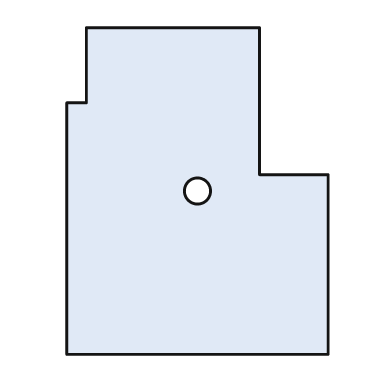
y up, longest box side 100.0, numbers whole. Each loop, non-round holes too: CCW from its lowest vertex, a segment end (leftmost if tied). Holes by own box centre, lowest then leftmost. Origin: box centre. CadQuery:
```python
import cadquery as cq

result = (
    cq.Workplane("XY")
    .moveTo(-40.0, -50.0)
    .lineTo(40.0, -50.0)
    .lineTo(40.0, 5.0)
    .lineTo(19.0, 5.0)
    .lineTo(19.0, 50.0)
    .lineTo(-34.0, 50.0)
    .lineTo(-34.0, 27.0)
    .lineTo(-40.0, 27.0)
    .close()
    .moveTo(0.0, 0.0)
    .circle(4.0)
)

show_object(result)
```